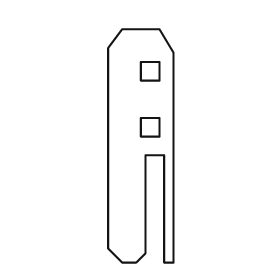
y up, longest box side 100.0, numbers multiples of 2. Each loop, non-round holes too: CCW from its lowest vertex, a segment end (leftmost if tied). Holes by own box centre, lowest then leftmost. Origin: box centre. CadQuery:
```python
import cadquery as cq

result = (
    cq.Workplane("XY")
    .moveTo(-8.0, -50.0)
    .lineTo(-2.0, -50.0)
    .lineTo(2.0, -46.0)
    .lineTo(2.0, -4.0)
    .lineTo(10.0, -4.0)
    .lineTo(10.0, -50.0)
    .lineTo(14.0, -50.0)
    .lineTo(14.0, 40.0)
    .lineTo(8.0, 50.0)
    .lineTo(-8.0, 50.0)
    .lineTo(-14.0, 42.0)
    .lineTo(-14.0, -44.0)
    .close()
    .moveTo(0.0, 4.0)
    .lineTo(8.0, 4.0)
    .lineTo(8.0, 12.0)
    .lineTo(0.0, 12.0)
    .close()
    .moveTo(0.0, 28.0)
    .lineTo(8.0, 28.0)
    .lineTo(8.0, 36.0)
    .lineTo(0.0, 36.0)
    .close()
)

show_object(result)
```